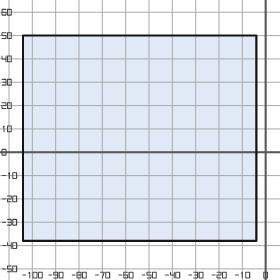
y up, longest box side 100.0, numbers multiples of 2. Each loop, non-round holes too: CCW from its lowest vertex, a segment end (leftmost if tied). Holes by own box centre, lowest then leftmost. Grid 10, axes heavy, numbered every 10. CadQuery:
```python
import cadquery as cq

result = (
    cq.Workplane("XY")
    .moveTo(-104.0, -38.0)
    .lineTo(-4.0, -38.0)
    .lineTo(-4.0, 50.0)
    .lineTo(-104.0, 50.0)
    .close()
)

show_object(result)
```